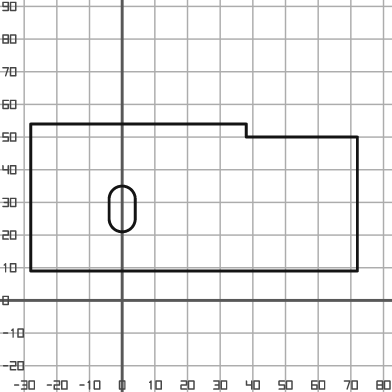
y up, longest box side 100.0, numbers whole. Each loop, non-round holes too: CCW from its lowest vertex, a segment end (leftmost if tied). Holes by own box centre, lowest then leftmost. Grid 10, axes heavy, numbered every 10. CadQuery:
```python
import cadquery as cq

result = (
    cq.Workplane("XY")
    .moveTo(-28.0, 9.0)
    .lineTo(72.0, 9.0)
    .lineTo(72.0, 50.0)
    .lineTo(38.0, 50.0)
    .lineTo(38.0, 54.0)
    .lineTo(-28.0, 54.0)
    .close()
    .moveTo(-4.0, 25.0)
    .threePointArc((0.0, 21.0), (4.0, 25.0))
    .lineTo(4.0, 31.0)
    .threePointArc((0.0, 35.0), (-4.0, 31.0))
    .close()
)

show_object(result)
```